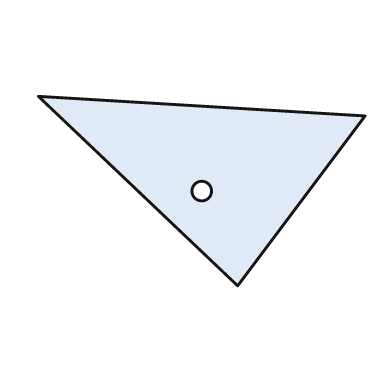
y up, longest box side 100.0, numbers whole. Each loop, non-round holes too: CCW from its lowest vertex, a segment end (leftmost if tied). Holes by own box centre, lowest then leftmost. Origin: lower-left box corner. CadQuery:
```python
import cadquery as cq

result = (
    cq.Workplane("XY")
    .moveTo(61.0, 0.0)
    .lineTo(100.0, 52.0)
    .lineTo(0.0, 58.0)
    .close()
    .moveTo(50.0, 29.0)
    .circle(3.0)
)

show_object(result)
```